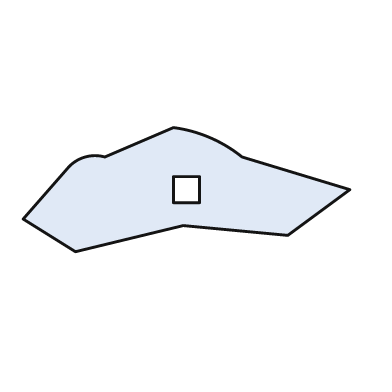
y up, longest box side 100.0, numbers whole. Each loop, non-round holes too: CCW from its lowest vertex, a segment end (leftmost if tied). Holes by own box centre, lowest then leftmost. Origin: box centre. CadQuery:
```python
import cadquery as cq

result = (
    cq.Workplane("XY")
    .moveTo(-34.0, -19.0)
    .lineTo(-1.0, -11.0)
    .lineTo(31.0, -14.0)
    .lineTo(50.0, 0.0)
    .lineTo(17.0, 10.0)
    .threePointArc((7.0, 16.0), (-4.0, 19.0))
    .lineTo(-25.0, 10.0)
    .threePointArc((-31.0, 10.0), (-36.0, 7.0))
    .lineTo(-50.0, -9.0)
    .close()
    .moveTo(-4.0, -4.0)
    .lineTo(4.0, -4.0)
    .lineTo(4.0, 4.0)
    .lineTo(-4.0, 4.0)
    .close()
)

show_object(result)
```